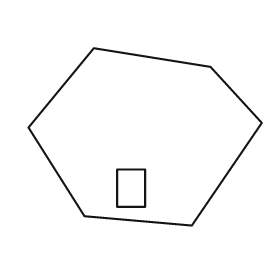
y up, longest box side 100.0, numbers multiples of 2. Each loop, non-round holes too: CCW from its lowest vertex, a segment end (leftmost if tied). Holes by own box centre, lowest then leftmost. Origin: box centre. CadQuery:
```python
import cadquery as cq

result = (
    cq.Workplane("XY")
    .moveTo(20.0, -38.0)
    .lineTo(50.0, 6.0)
    .lineTo(28.0, 30.0)
    .lineTo(-22.0, 38.0)
    .lineTo(-50.0, 4.0)
    .lineTo(-26.0, -34.0)
    .close()
    .moveTo(-12.0, -30.0)
    .lineTo(0.0, -30.0)
    .lineTo(0.0, -14.0)
    .lineTo(-12.0, -14.0)
    .close()
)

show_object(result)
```